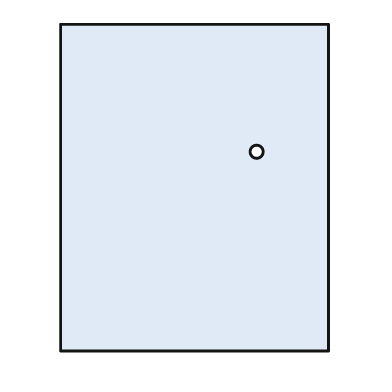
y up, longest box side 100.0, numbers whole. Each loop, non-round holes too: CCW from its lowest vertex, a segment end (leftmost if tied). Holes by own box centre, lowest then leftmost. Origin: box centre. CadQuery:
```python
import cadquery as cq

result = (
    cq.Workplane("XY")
    .moveTo(-41.0, -50.0)
    .lineTo(41.0, -50.0)
    .lineTo(41.0, 50.0)
    .lineTo(-41.0, 50.0)
    .close()
    .moveTo(19.0, 11.0)
    .circle(2.0)
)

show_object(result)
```